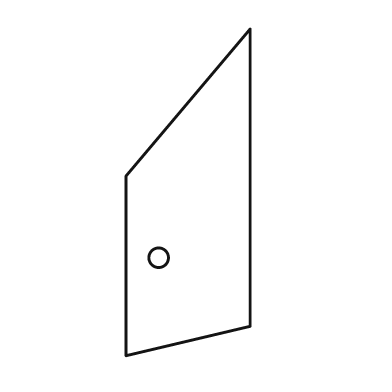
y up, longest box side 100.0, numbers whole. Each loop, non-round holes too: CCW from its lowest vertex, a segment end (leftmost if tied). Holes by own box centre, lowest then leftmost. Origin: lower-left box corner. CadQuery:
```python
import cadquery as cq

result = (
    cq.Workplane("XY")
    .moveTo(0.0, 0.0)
    .lineTo(38.0, 9.0)
    .lineTo(38.0, 100.0)
    .lineTo(0.0, 55.0)
    .close()
    .moveTo(10.0, 30.0)
    .circle(3.0)
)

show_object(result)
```